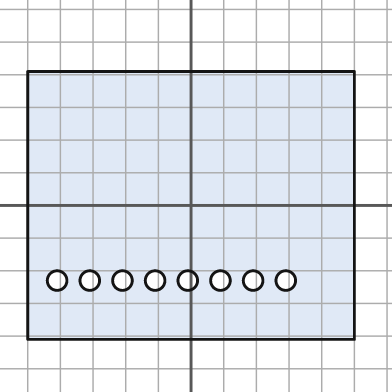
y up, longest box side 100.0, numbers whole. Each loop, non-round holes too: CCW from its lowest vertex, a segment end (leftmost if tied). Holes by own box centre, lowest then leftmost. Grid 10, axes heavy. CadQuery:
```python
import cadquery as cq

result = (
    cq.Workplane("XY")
    .moveTo(-50.0, -41.0)
    .lineTo(50.0, -41.0)
    .lineTo(50.0, 41.0)
    .lineTo(-50.0, 41.0)
    .close()
    .moveTo(-41.0, -23.0)
    .circle(3.0)
    .moveTo(-31.0, -23.0)
    .circle(3.0)
    .moveTo(-21.0, -23.0)
    .circle(3.0)
    .moveTo(-11.0, -23.0)
    .circle(3.0)
    .moveTo(-1.0, -23.0)
    .circle(3.0)
    .moveTo(9.0, -23.0)
    .circle(3.0)
    .moveTo(19.0, -23.0)
    .circle(3.0)
    .moveTo(29.0, -23.0)
    .circle(3.0)
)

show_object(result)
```